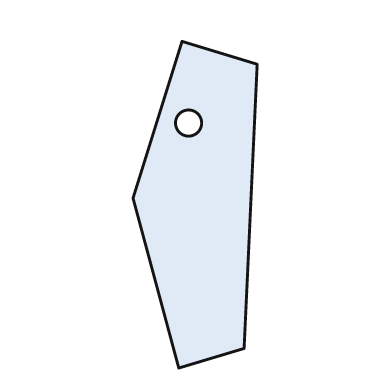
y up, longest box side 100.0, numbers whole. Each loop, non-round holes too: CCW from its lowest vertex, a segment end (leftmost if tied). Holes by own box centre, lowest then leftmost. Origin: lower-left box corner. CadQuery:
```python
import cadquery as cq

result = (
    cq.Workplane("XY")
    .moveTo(14.0, 0.0)
    .lineTo(34.0, 6.0)
    .lineTo(38.0, 93.0)
    .lineTo(15.0, 100.0)
    .lineTo(0.0, 52.0)
    .close()
    .moveTo(17.0, 75.0)
    .circle(4.0)
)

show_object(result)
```